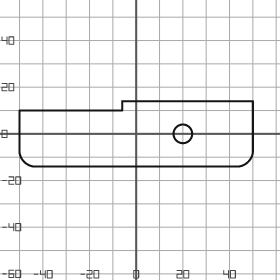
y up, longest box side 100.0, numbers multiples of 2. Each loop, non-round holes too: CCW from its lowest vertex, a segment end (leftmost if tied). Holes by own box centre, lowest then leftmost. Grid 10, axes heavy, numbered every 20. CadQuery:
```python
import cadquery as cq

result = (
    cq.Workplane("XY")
    .moveTo(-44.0, -14.0)
    .lineTo(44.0, -14.0)
    .threePointArc((48.0, -12.0), (50.0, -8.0))
    .lineTo(50.0, 14.0)
    .lineTo(-6.0, 14.0)
    .lineTo(-6.0, 10.0)
    .lineTo(-50.0, 10.0)
    .lineTo(-50.0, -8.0)
    .threePointArc((-48.0, -12.0), (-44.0, -14.0))
    .close()
    .moveTo(20.0, 0.0)
    .circle(4.0)
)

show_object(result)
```